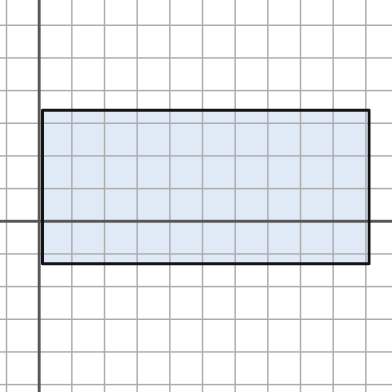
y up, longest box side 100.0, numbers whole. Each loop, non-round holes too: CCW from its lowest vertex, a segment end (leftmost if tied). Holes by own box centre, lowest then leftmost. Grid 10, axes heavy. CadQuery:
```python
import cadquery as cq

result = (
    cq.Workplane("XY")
    .moveTo(1.0, -13.0)
    .lineTo(101.0, -13.0)
    .lineTo(101.0, 34.0)
    .lineTo(1.0, 34.0)
    .close()
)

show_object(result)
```